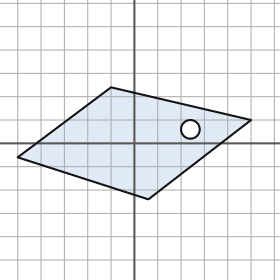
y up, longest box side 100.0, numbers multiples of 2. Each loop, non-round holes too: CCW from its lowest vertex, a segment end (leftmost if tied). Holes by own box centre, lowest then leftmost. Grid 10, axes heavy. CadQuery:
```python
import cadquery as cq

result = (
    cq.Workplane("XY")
    .moveTo(6.0, -24.0)
    .lineTo(50.0, 10.0)
    .lineTo(-10.0, 24.0)
    .lineTo(-50.0, -6.0)
    .close()
    .moveTo(24.0, 6.0)
    .circle(4.0)
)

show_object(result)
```